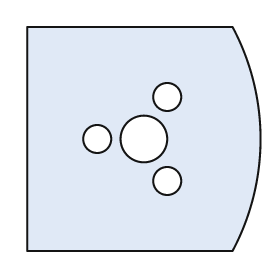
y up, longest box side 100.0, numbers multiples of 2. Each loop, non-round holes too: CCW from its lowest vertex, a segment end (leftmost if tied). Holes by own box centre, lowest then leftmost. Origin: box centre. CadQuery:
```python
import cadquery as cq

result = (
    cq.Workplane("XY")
    .moveTo(-50.0, -48.0)
    .lineTo(38.0, -48.0)
    .threePointArc((50.0, 0.0), (38.0, 48.0))
    .lineTo(-50.0, 48.0)
    .close()
    .moveTo(10.0, -18.0)
    .circle(6.0)
    .moveTo(-20.0, 0.0)
    .circle(6.0)
    .moveTo(0.0, 0.0)
    .circle(10.0)
    .moveTo(10.0, 18.0)
    .circle(6.0)
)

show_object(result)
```